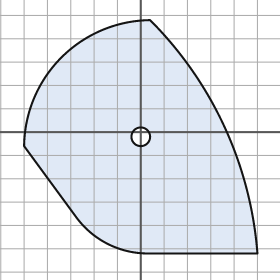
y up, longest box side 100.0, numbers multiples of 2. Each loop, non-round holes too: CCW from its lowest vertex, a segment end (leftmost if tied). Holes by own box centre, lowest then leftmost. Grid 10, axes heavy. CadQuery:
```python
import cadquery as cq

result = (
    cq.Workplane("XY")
    .moveTo(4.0, -52.0)
    .lineTo(50.0, -52.0)
    .threePointArc((36.0, 2.0), (4.0, 48.0))
    .threePointArc((-34.0, 32.0), (-50.0, -6.0))
    .lineTo(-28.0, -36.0)
    .threePointArc((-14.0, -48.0), (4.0, -52.0))
    .close()
    .moveTo(0.0, -2.0)
    .circle(4.0)
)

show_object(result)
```